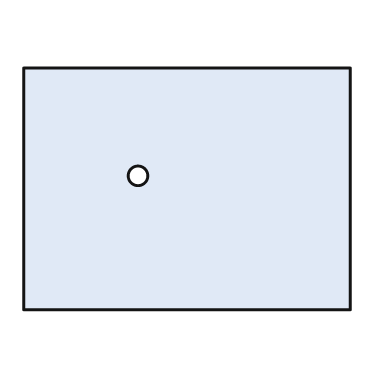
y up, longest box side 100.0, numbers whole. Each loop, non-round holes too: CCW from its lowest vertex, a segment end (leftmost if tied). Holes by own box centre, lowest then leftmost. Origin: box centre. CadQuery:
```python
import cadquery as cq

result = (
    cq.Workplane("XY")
    .moveTo(-50.0, -37.0)
    .lineTo(50.0, -37.0)
    .lineTo(50.0, 37.0)
    .lineTo(-50.0, 37.0)
    .close()
    .moveTo(-15.0, 4.0)
    .circle(3.0)
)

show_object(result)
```